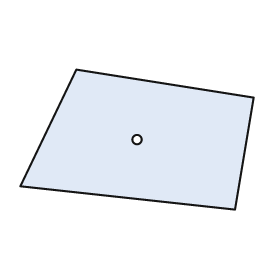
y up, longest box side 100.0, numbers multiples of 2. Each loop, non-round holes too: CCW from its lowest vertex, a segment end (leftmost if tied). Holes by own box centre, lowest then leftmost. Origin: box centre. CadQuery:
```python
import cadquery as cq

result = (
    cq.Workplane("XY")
    .moveTo(42.0, -30.0)
    .lineTo(50.0, 18.0)
    .lineTo(-26.0, 30.0)
    .lineTo(-50.0, -20.0)
    .close()
    .moveTo(0.0, 0.0)
    .circle(2.0)
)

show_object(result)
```